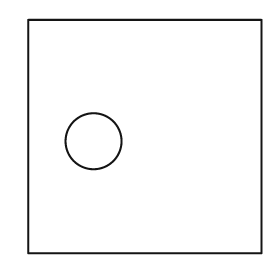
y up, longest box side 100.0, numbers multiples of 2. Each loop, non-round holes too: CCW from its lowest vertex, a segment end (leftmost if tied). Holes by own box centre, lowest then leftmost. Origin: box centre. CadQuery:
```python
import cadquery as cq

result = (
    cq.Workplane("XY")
    .moveTo(-50.0, -50.0)
    .lineTo(50.0, -50.0)
    .lineTo(50.0, 50.0)
    .lineTo(-50.0, 50.0)
    .close()
    .moveTo(-22.0, -2.0)
    .circle(12.0)
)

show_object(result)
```